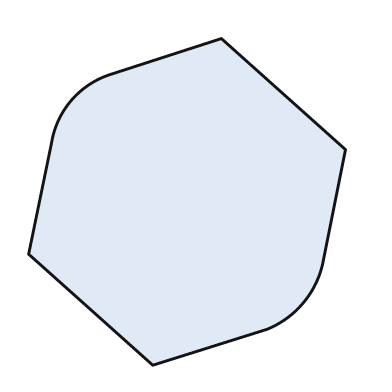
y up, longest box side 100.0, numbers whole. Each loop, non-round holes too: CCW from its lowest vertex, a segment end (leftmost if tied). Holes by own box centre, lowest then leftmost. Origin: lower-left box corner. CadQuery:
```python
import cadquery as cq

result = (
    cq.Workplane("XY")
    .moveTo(38.0, 0.0)
    .lineTo(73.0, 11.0)
    .threePointArc((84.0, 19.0), (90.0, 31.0))
    .lineTo(97.0, 66.0)
    .lineTo(59.0, 100.0)
    .lineTo(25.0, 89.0)
    .threePointArc((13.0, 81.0), (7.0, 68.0))
    .lineTo(0.0, 34.0)
    .close()
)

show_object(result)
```